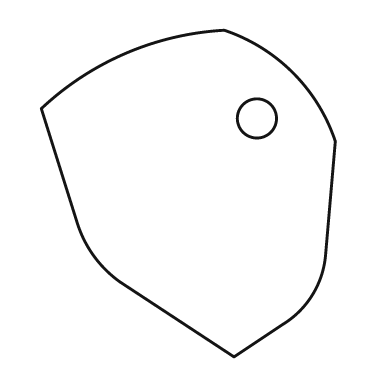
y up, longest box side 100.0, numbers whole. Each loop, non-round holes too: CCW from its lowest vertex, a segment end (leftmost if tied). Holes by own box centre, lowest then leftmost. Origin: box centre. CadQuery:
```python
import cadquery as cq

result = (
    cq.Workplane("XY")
    .moveTo(14.0, -50.0)
    .lineTo(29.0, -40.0)
    .threePointArc((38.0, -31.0), (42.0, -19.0))
    .lineTo(45.0, 16.0)
    .threePointArc((32.0, 37.0), (11.0, 50.0))
    .threePointArc((-19.0, 43.0), (-45.0, 26.0))
    .lineTo(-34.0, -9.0)
    .threePointArc((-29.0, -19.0), (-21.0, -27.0))
    .close()
    .moveTo(21.0, 23.0)
    .circle(6.0)
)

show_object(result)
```